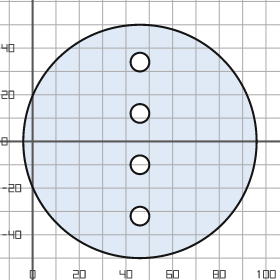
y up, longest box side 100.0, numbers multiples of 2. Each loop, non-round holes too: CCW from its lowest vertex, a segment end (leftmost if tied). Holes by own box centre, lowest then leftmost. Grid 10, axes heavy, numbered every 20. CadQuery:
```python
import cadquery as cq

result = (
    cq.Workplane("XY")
    .moveTo(46.0, 0.0)
    .circle(50.0)
    .moveTo(46.0, -32.0)
    .circle(4.0)
    .moveTo(46.0, -10.0)
    .circle(4.0)
    .moveTo(46.0, 12.0)
    .circle(4.0)
    .moveTo(46.0, 34.0)
    .circle(4.0)
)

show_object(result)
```